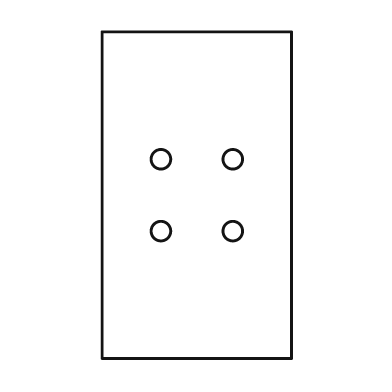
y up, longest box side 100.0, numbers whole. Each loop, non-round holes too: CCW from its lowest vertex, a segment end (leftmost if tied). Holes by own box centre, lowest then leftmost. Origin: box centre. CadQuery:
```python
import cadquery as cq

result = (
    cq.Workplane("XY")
    .moveTo(-29.0, -50.0)
    .lineTo(29.0, -50.0)
    .lineTo(29.0, 50.0)
    .lineTo(-29.0, 50.0)
    .close()
    .moveTo(-11.0, -11.0)
    .circle(3.0)
    .moveTo(11.0, -11.0)
    .circle(3.0)
    .moveTo(-11.0, 11.0)
    .circle(3.0)
    .moveTo(11.0, 11.0)
    .circle(3.0)
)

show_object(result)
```